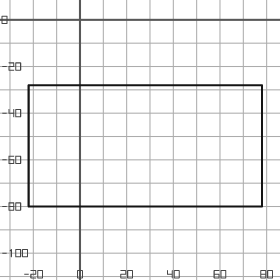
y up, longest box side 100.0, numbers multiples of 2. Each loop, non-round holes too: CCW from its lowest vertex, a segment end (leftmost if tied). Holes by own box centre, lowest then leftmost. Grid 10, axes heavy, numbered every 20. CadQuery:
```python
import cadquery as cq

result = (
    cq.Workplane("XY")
    .moveTo(-22.0, -80.0)
    .lineTo(78.0, -80.0)
    .lineTo(78.0, -28.0)
    .lineTo(-22.0, -28.0)
    .close()
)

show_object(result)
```